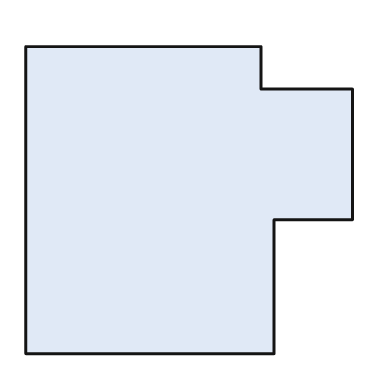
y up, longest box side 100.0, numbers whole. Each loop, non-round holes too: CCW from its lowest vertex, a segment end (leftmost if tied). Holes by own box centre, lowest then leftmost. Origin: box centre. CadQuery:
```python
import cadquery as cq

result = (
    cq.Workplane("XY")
    .moveTo(-50.0, -47.0)
    .lineTo(26.0, -47.0)
    .lineTo(26.0, -6.0)
    .lineTo(50.0, -6.0)
    .lineTo(50.0, 34.0)
    .lineTo(22.0, 34.0)
    .lineTo(22.0, 47.0)
    .lineTo(-50.0, 47.0)
    .close()
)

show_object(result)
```